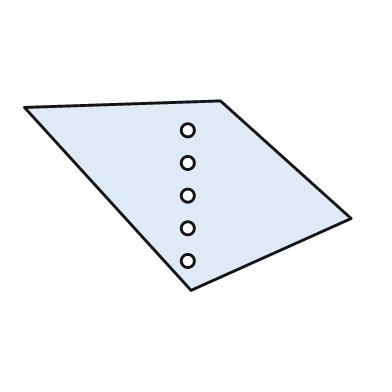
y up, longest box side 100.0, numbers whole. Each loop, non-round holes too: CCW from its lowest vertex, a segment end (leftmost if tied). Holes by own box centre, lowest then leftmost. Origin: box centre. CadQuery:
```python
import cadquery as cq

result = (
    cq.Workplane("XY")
    .moveTo(1.0, -29.0)
    .lineTo(50.0, -7.0)
    .lineTo(10.0, 29.0)
    .lineTo(-50.0, 27.0)
    .close()
    .moveTo(0.0, -20.0)
    .circle(2.0)
    .moveTo(0.0, -10.0)
    .circle(2.0)
    .moveTo(0.0, 0.0)
    .circle(2.0)
    .moveTo(0.0, 10.0)
    .circle(2.0)
    .moveTo(0.0, 20.0)
    .circle(2.0)
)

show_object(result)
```